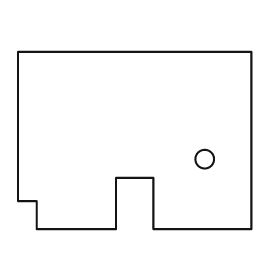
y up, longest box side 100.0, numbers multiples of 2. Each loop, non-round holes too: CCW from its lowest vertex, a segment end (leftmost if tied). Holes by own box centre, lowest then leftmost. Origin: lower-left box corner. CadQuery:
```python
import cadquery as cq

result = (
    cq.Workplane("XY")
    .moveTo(8.0, 0.0)
    .lineTo(42.0, 0.0)
    .lineTo(42.0, 22.0)
    .lineTo(58.0, 22.0)
    .lineTo(58.0, 0.0)
    .lineTo(100.0, 0.0)
    .lineTo(100.0, 76.0)
    .lineTo(0.0, 76.0)
    .lineTo(0.0, 12.0)
    .lineTo(8.0, 12.0)
    .close()
    .moveTo(80.0, 30.0)
    .circle(4.0)
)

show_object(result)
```